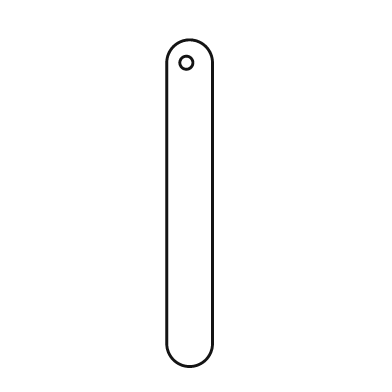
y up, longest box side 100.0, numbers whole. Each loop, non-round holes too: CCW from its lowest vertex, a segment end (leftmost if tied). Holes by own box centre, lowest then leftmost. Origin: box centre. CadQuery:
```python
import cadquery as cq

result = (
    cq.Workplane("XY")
    .moveTo(-7.0, -43.0)
    .threePointArc((0.0, -50.0), (7.0, -43.0))
    .lineTo(7.0, 43.0)
    .threePointArc((0.0, 50.0), (-7.0, 43.0))
    .close()
    .moveTo(-1.0, 43.0)
    .circle(2.0)
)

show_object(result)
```